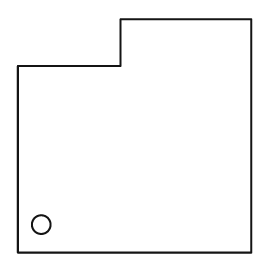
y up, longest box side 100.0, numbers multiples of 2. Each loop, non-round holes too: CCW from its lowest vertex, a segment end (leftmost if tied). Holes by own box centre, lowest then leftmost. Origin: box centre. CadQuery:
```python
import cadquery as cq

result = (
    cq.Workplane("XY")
    .moveTo(-50.0, -50.0)
    .lineTo(50.0, -50.0)
    .lineTo(50.0, 50.0)
    .lineTo(-6.0, 50.0)
    .lineTo(-6.0, 30.0)
    .lineTo(-50.0, 30.0)
    .close()
    .moveTo(-40.0, -38.0)
    .circle(4.0)
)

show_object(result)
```